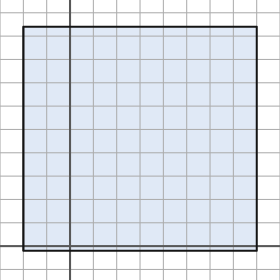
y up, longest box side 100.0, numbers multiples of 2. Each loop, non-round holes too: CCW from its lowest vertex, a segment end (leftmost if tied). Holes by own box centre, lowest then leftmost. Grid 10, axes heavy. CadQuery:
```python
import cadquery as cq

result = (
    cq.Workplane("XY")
    .moveTo(-20.0, -2.0)
    .lineTo(80.0, -2.0)
    .lineTo(80.0, 94.0)
    .lineTo(-20.0, 94.0)
    .close()
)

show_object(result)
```